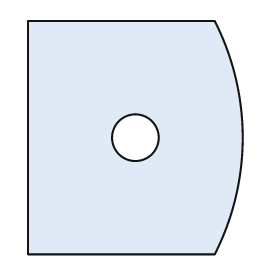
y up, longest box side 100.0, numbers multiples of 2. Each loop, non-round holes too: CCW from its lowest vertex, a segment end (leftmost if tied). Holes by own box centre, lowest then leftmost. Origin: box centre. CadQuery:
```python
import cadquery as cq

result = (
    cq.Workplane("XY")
    .moveTo(-46.0, -50.0)
    .lineTo(34.0, -50.0)
    .threePointArc((46.0, 0.0), (34.0, 50.0))
    .lineTo(-46.0, 50.0)
    .close()
    .moveTo(0.0, 0.0)
    .circle(10.0)
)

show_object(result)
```